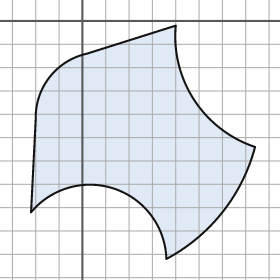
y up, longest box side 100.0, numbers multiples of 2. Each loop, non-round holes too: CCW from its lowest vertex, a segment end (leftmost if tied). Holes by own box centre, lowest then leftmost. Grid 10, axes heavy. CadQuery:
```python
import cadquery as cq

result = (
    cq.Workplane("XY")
    .moveTo(36.0, -102.0)
    .threePointArc((60.0, -82.0), (74.0, -54.0))
    .threePointArc((48.0, -34.0), (40.0, -2.0))
    .lineTo(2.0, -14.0)
    .threePointArc((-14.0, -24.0), (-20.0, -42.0))
    .lineTo(-22.0, -82.0)
    .threePointArc((14.0, -72.0), (36.0, -102.0))
    .close()
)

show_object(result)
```